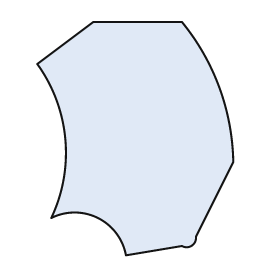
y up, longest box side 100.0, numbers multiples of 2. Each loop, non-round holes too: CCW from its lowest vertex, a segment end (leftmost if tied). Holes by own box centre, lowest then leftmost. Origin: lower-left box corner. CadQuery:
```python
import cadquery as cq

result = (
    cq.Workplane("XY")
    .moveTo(38.0, 0.0)
    .lineTo(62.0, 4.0)
    .threePointArc((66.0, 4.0), (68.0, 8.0))
    .lineTo(84.0, 40.0)
    .threePointArc((78.0, 72.0), (62.0, 100.0))
    .lineTo(24.0, 100.0)
    .lineTo(0.0, 82.0)
    .threePointArc((12.0, 50.0), (6.0, 16.0))
    .threePointArc((26.0, 16.0), (38.0, 0.0))
    .close()
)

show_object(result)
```